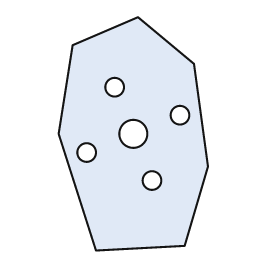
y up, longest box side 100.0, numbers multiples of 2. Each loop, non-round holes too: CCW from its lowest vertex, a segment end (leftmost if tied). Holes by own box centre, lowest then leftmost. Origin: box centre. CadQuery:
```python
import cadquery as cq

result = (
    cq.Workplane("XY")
    .moveTo(-16.0, -50.0)
    .lineTo(22.0, -48.0)
    .lineTo(32.0, -14.0)
    .lineTo(26.0, 30.0)
    .lineTo(2.0, 50.0)
    .lineTo(-26.0, 38.0)
    .lineTo(-32.0, 0.0)
    .close()
    .moveTo(8.0, -20.0)
    .circle(4.0)
    .moveTo(-20.0, -8.0)
    .circle(4.0)
    .moveTo(0.0, 0.0)
    .circle(6.0)
    .moveTo(20.0, 8.0)
    .circle(4.0)
    .moveTo(-8.0, 20.0)
    .circle(4.0)
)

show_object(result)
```